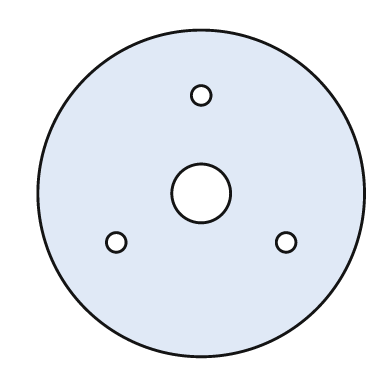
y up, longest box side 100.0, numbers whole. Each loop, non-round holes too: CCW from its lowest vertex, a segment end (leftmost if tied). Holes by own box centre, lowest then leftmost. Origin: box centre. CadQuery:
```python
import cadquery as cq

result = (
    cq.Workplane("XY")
    .moveTo(0.0, 0.0)
    .circle(50.0)
    .moveTo(-26.0, -15.0)
    .circle(3.0)
    .moveTo(26.0, -15.0)
    .circle(3.0)
    .moveTo(0.0, 0.0)
    .circle(9.0)
    .moveTo(0.0, 30.0)
    .circle(3.0)
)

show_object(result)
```